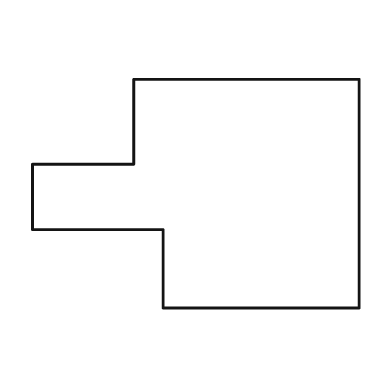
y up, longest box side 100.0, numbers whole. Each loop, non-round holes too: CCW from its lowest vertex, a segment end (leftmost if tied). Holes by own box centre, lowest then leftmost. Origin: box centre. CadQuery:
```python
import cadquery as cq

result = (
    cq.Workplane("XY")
    .moveTo(-10.0, -35.0)
    .lineTo(50.0, -35.0)
    .lineTo(50.0, 35.0)
    .lineTo(-19.0, 35.0)
    .lineTo(-19.0, 9.0)
    .lineTo(-50.0, 9.0)
    .lineTo(-50.0, -11.0)
    .lineTo(-10.0, -11.0)
    .close()
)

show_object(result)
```